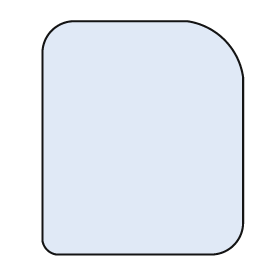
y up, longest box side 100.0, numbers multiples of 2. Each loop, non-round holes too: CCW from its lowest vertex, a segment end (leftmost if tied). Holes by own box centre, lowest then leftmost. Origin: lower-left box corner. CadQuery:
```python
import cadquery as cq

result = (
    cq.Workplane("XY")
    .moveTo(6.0, 0.0)
    .lineTo(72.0, 0.0)
    .threePointArc((82.0, 4.0), (86.0, 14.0))
    .lineTo(86.0, 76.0)
    .threePointArc((78.0, 92.0), (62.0, 100.0))
    .lineTo(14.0, 100.0)
    .threePointArc((4.0, 96.0), (0.0, 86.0))
    .lineTo(0.0, 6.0)
    .threePointArc((2.0, 2.0), (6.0, 0.0))
    .close()
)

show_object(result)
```